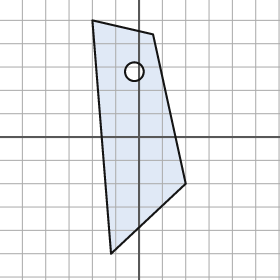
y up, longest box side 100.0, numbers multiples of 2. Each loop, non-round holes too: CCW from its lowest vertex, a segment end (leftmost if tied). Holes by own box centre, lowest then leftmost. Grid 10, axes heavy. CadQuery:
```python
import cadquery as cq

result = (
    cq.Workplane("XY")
    .moveTo(-12.0, -50.0)
    .lineTo(20.0, -20.0)
    .lineTo(6.0, 44.0)
    .lineTo(-20.0, 50.0)
    .close()
    .moveTo(-2.0, 28.0)
    .circle(4.0)
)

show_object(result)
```